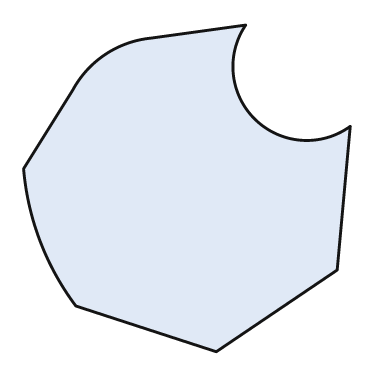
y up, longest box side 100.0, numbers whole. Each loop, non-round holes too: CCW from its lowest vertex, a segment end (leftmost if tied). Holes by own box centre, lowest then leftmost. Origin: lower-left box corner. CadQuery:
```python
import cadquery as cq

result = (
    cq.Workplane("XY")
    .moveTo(59.0, 0.0)
    .lineTo(96.0, 25.0)
    .lineTo(100.0, 69.0)
    .threePointArc((71.0, 71.0), (68.0, 100.0))
    .lineTo(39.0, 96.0)
    .threePointArc((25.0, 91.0), (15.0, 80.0))
    .lineTo(0.0, 56.0)
    .threePointArc((5.0, 34.0), (16.0, 14.0))
    .close()
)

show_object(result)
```